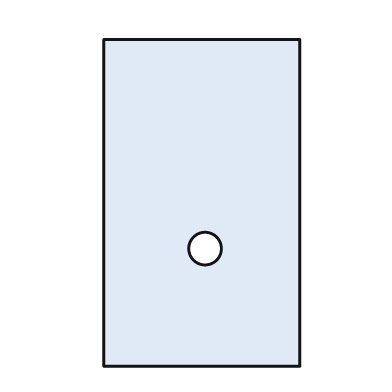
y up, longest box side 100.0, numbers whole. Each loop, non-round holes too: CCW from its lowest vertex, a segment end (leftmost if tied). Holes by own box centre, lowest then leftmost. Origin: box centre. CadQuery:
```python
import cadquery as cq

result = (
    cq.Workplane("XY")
    .moveTo(-30.0, -50.0)
    .lineTo(30.0, -50.0)
    .lineTo(30.0, 50.0)
    .lineTo(-30.0, 50.0)
    .close()
    .moveTo(1.0, -14.0)
    .circle(5.0)
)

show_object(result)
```